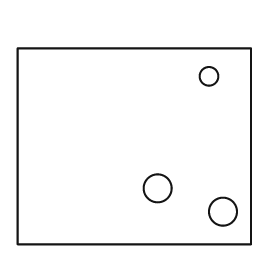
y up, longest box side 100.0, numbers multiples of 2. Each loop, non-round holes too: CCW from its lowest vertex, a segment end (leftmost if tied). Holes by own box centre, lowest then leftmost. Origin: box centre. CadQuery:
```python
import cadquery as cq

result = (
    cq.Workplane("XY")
    .moveTo(-50.0, -42.0)
    .lineTo(50.0, -42.0)
    .lineTo(50.0, 42.0)
    .lineTo(-50.0, 42.0)
    .close()
    .moveTo(38.0, -28.0)
    .circle(6.0)
    .moveTo(10.0, -18.0)
    .circle(6.0)
    .moveTo(32.0, 30.0)
    .circle(4.0)
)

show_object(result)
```